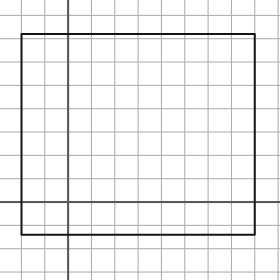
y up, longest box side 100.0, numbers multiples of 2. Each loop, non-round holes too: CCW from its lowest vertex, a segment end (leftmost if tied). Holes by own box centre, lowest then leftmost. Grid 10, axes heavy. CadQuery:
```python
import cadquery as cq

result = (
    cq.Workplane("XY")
    .moveTo(-20.0, -14.0)
    .lineTo(80.0, -14.0)
    .lineTo(80.0, 72.0)
    .lineTo(-20.0, 72.0)
    .close()
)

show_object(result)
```